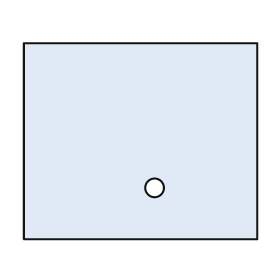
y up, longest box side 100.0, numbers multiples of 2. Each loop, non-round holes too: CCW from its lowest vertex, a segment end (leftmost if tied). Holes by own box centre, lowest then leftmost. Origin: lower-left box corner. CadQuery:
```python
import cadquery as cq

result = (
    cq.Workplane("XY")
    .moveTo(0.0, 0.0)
    .lineTo(100.0, 0.0)
    .lineTo(100.0, 84.0)
    .lineTo(0.0, 84.0)
    .close()
    .moveTo(56.0, 22.0)
    .circle(4.0)
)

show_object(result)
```